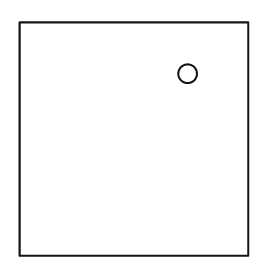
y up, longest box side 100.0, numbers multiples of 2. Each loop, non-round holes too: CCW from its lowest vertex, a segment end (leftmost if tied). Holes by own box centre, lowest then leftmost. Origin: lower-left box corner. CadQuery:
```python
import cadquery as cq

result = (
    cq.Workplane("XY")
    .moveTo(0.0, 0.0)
    .lineTo(98.0, 0.0)
    .lineTo(98.0, 100.0)
    .lineTo(0.0, 100.0)
    .close()
    .moveTo(72.0, 78.0)
    .circle(4.0)
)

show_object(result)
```